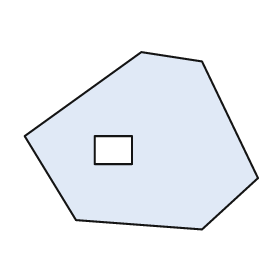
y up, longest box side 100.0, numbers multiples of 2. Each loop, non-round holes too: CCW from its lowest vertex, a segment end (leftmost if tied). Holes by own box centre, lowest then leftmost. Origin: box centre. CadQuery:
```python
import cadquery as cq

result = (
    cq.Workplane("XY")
    .moveTo(26.0, -38.0)
    .lineTo(50.0, -16.0)
    .lineTo(26.0, 34.0)
    .lineTo(0.0, 38.0)
    .lineTo(-50.0, 2.0)
    .lineTo(-28.0, -34.0)
    .close()
    .moveTo(-20.0, -10.0)
    .lineTo(-4.0, -10.0)
    .lineTo(-4.0, 2.0)
    .lineTo(-20.0, 2.0)
    .close()
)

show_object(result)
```